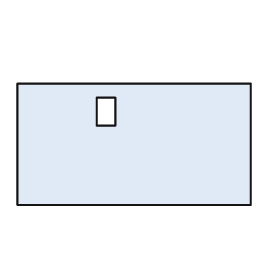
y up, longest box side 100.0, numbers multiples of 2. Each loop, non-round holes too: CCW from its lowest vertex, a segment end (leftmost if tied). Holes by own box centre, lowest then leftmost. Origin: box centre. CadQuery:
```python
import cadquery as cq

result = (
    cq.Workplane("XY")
    .moveTo(-50.0, -26.0)
    .lineTo(50.0, -26.0)
    .lineTo(50.0, 26.0)
    .lineTo(-50.0, 26.0)
    .close()
    .moveTo(-16.0, 8.0)
    .lineTo(-8.0, 8.0)
    .lineTo(-8.0, 20.0)
    .lineTo(-16.0, 20.0)
    .close()
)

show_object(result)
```